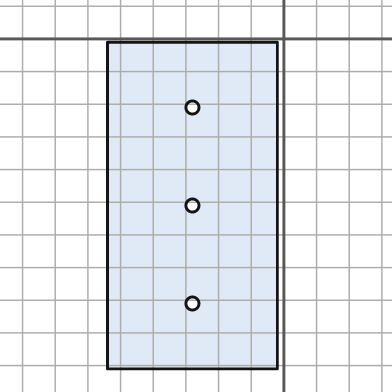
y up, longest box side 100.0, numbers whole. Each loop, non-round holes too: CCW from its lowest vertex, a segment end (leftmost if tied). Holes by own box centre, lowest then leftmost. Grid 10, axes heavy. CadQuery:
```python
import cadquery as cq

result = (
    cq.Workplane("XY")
    .moveTo(-54.0, -101.0)
    .lineTo(-2.0, -101.0)
    .lineTo(-2.0, -1.0)
    .lineTo(-54.0, -1.0)
    .close()
    .moveTo(-28.0, -81.0)
    .circle(2.0)
    .moveTo(-28.0, -51.0)
    .circle(2.0)
    .moveTo(-28.0, -21.0)
    .circle(2.0)
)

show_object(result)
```